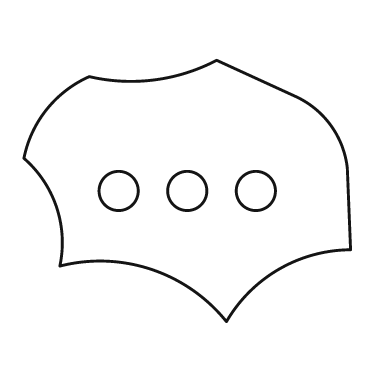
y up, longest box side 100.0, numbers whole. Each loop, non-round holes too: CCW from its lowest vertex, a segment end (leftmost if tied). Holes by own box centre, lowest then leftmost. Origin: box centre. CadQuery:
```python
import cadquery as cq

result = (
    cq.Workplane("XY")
    .moveTo(12.0, -40.0)
    .threePointArc((28.0, -24.0), (50.0, -18.0))
    .lineTo(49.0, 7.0)
    .threePointArc((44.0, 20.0), (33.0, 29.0))
    .lineTo(9.0, 40.0)
    .threePointArc((-10.0, 34.0), (-30.0, 35.0))
    .threePointArc((-43.0, 25.0), (-50.0, 10.0))
    .threePointArc((-40.0, -5.0), (-39.0, -23.0))
    .threePointArc((-11.0, -24.0), (12.0, -40.0))
    .close()
    .moveTo(-21.0, 0.0)
    .circle(6.0)
    .moveTo(0.0, 0.0)
    .circle(6.0)
    .moveTo(21.0, 0.0)
    .circle(6.0)
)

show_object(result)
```